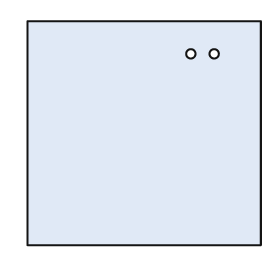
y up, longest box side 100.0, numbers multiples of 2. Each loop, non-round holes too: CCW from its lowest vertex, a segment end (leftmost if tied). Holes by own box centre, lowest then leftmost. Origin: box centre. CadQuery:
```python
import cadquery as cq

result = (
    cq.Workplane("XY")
    .moveTo(-50.0, -48.0)
    .lineTo(50.0, -48.0)
    .lineTo(50.0, 48.0)
    .lineTo(-50.0, 48.0)
    .close()
    .moveTo(20.0, 34.0)
    .circle(2.0)
    .moveTo(30.0, 34.0)
    .circle(2.0)
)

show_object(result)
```